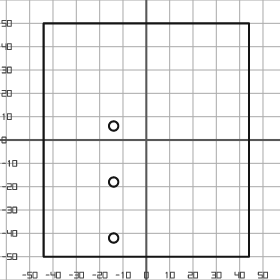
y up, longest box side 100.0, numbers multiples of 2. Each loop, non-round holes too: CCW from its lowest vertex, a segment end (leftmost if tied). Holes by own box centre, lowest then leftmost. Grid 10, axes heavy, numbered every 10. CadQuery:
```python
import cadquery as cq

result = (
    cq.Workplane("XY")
    .moveTo(-44.0, -50.0)
    .lineTo(44.0, -50.0)
    .lineTo(44.0, 50.0)
    .lineTo(-44.0, 50.0)
    .close()
    .moveTo(-14.0, -42.0)
    .circle(2.0)
    .moveTo(-14.0, -18.0)
    .circle(2.0)
    .moveTo(-14.0, 6.0)
    .circle(2.0)
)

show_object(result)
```